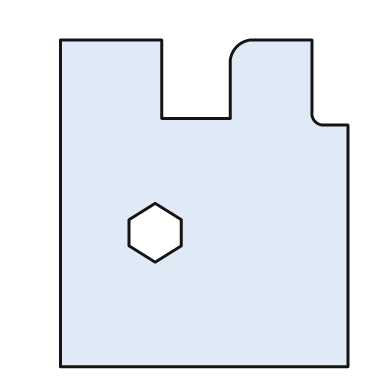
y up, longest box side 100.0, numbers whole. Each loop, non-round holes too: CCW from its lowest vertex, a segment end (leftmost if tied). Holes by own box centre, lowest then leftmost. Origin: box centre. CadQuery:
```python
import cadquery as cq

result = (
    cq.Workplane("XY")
    .moveTo(-44.0, -50.0)
    .lineTo(44.0, -50.0)
    .lineTo(44.0, 24.0)
    .lineTo(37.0, 24.0)
    .threePointArc((34.0, 25.0), (33.0, 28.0))
    .lineTo(33.0, 50.0)
    .lineTo(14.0, 50.0)
    .threePointArc((10.0, 48.0), (8.0, 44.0))
    .lineTo(8.0, 26.0)
    .lineTo(-13.0, 26.0)
    .lineTo(-13.0, 50.0)
    .lineTo(-44.0, 50.0)
    .close()
    .moveTo(-15.0, -18.0)
    .lineTo(-7.0, -13.0)
    .lineTo(-7.0, -5.0)
    .lineTo(-15.0, 0.0)
    .lineTo(-23.0, -5.0)
    .lineTo(-23.0, -13.0)
    .close()
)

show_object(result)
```